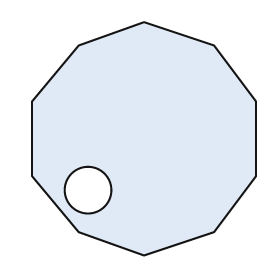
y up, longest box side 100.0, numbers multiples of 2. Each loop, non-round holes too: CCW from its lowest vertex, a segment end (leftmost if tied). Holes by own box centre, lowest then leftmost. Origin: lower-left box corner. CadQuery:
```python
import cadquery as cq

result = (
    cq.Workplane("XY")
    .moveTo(48.0, 0.0)
    .lineTo(78.0, 10.0)
    .lineTo(96.0, 34.0)
    .lineTo(96.0, 66.0)
    .lineTo(78.0, 90.0)
    .lineTo(48.0, 100.0)
    .lineTo(20.0, 90.0)
    .lineTo(0.0, 66.0)
    .lineTo(0.0, 34.0)
    .lineTo(20.0, 10.0)
    .close()
    .moveTo(24.0, 28.0)
    .circle(10.0)
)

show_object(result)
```